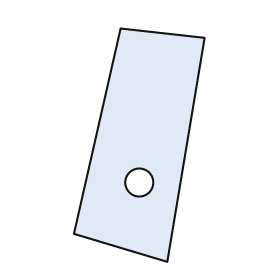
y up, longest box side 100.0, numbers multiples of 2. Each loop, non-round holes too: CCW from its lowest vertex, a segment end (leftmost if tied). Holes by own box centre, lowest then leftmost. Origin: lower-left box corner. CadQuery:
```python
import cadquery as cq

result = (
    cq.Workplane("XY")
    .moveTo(40.0, 0.0)
    .lineTo(56.0, 96.0)
    .lineTo(20.0, 100.0)
    .lineTo(0.0, 12.0)
    .close()
    .moveTo(28.0, 34.0)
    .circle(6.0)
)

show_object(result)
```